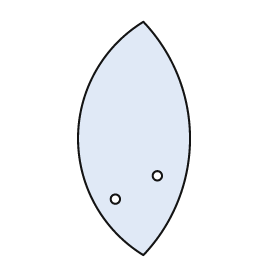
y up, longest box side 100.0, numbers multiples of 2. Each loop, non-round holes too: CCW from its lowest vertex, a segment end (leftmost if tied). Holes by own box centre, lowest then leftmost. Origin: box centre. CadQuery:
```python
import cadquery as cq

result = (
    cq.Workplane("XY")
    .moveTo(4.0, -50.0)
    .threePointArc((24.0, 0.0), (4.0, 50.0))
    .threePointArc((-24.0, 0.0), (4.0, -50.0))
    .close()
    .moveTo(-8.0, -26.0)
    .circle(2.0)
    .moveTo(10.0, -16.0)
    .circle(2.0)
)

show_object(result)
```